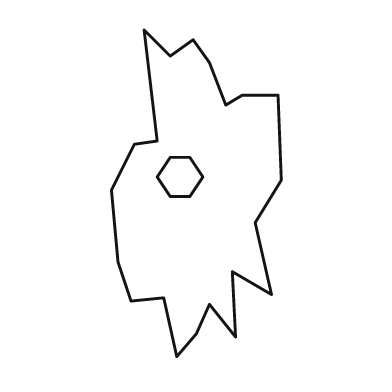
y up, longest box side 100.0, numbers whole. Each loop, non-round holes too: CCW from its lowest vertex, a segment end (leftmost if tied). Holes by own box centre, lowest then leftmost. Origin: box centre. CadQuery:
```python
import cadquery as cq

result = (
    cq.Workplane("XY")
    .moveTo(-6.0, -50.0)
    .lineTo(0.0, -43.0)
    .lineTo(4.0, -34.0)
    .lineTo(12.0, -44.0)
    .lineTo(11.0, -24.0)
    .lineTo(23.0, -31.0)
    .lineTo(18.0, -9.0)
    .lineTo(26.0, 4.0)
    .lineTo(25.0, 30.0)
    .lineTo(14.0, 30.0)
    .lineTo(9.0, 27.0)
    .lineTo(4.0, 40.0)
    .lineTo(-1.0, 47.0)
    .lineTo(-8.0, 42.0)
    .lineTo(-16.0, 50.0)
    .lineTo(-12.0, 16.0)
    .lineTo(-19.0, 15.0)
    .lineTo(-26.0, 1.0)
    .lineTo(-24.0, -21.0)
    .lineTo(-20.0, -33.0)
    .lineTo(-10.0, -32.0)
    .close()
    .moveTo(-8.0, -1.0)
    .lineTo(-2.0, -1.0)
    .lineTo(2.0, 5.0)
    .lineTo(-2.0, 11.0)
    .lineTo(-8.0, 11.0)
    .lineTo(-12.0, 5.0)
    .close()
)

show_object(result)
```